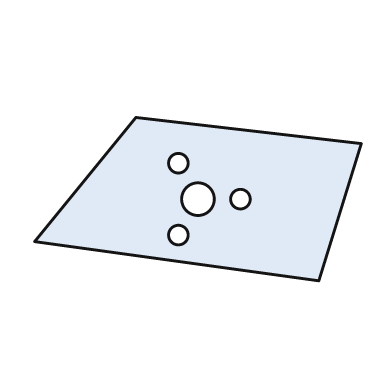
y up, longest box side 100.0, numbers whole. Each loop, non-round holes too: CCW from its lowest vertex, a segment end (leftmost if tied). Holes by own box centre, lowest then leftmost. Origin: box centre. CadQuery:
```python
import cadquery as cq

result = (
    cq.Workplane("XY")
    .moveTo(37.0, -25.0)
    .lineTo(50.0, 17.0)
    .lineTo(-19.0, 25.0)
    .lineTo(-50.0, -13.0)
    .close()
    .moveTo(-6.0, -11.0)
    .circle(3.0)
    .moveTo(0.0, 0.0)
    .circle(5.0)
    .moveTo(13.0, 0.0)
    .circle(3.0)
    .moveTo(-6.0, 11.0)
    .circle(3.0)
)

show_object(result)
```